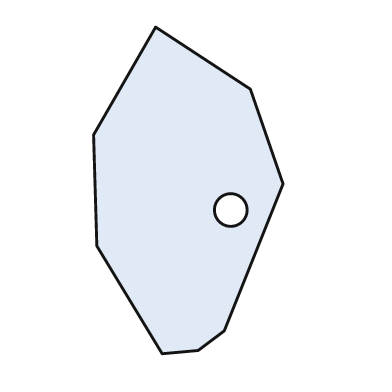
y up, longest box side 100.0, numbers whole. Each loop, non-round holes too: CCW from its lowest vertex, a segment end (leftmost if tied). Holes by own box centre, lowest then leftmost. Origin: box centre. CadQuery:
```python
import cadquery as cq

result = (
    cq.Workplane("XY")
    .moveTo(-8.0, -50.0)
    .lineTo(3.0, -49.0)
    .lineTo(11.0, -43.0)
    .lineTo(29.0, 2.0)
    .lineTo(19.0, 31.0)
    .lineTo(-10.0, 50.0)
    .lineTo(-29.0, 17.0)
    .lineTo(-28.0, -17.0)
    .close()
    .moveTo(13.0, -6.0)
    .circle(5.0)
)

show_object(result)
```